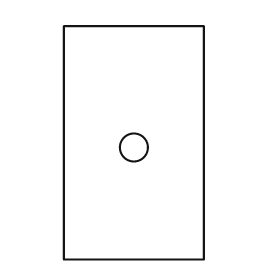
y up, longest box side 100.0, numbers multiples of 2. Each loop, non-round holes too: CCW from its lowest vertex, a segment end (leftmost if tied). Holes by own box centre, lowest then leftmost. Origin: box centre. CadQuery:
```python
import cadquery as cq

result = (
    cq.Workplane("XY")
    .moveTo(-30.0, -50.0)
    .lineTo(30.0, -50.0)
    .lineTo(30.0, 50.0)
    .lineTo(-30.0, 50.0)
    .close()
    .moveTo(0.0, -2.0)
    .circle(6.0)
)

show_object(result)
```